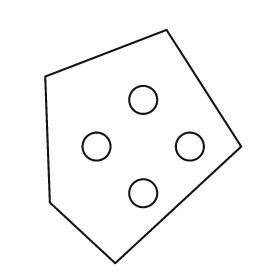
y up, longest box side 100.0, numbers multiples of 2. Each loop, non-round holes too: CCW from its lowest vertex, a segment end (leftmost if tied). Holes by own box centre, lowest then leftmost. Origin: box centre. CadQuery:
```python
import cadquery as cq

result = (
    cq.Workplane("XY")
    .moveTo(-12.0, -50.0)
    .lineTo(42.0, 0.0)
    .lineTo(10.0, 50.0)
    .lineTo(-42.0, 30.0)
    .lineTo(-40.0, -24.0)
    .close()
    .moveTo(0.0, -20.0)
    .circle(6.0)
    .moveTo(-20.0, 0.0)
    .circle(6.0)
    .moveTo(20.0, 0.0)
    .circle(6.0)
    .moveTo(0.0, 20.0)
    .circle(6.0)
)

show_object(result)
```